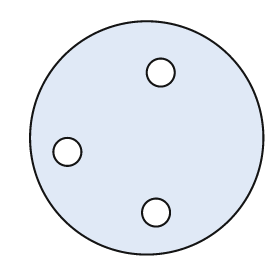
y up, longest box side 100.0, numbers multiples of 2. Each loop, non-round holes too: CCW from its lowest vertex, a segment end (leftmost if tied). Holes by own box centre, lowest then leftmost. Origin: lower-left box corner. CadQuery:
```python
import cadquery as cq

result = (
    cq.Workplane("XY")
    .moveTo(50.0, 50.0)
    .circle(50.0)
    .moveTo(54.0, 18.0)
    .circle(6.0)
    .moveTo(16.0, 44.0)
    .circle(6.0)
    .moveTo(56.0, 78.0)
    .circle(6.0)
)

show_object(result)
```